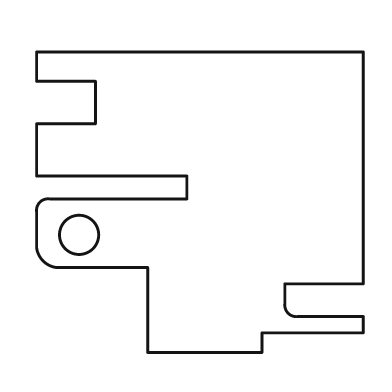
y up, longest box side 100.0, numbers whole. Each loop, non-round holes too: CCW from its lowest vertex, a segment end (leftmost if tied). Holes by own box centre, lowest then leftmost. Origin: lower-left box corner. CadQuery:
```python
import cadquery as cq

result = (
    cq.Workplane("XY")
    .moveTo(34.0, 0.0)
    .lineTo(69.0, 0.0)
    .lineTo(69.0, 6.0)
    .lineTo(100.0, 6.0)
    .lineTo(100.0, 11.0)
    .lineTo(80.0, 11.0)
    .threePointArc((77.0, 12.0), (76.0, 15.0))
    .lineTo(76.0, 21.0)
    .lineTo(100.0, 21.0)
    .lineTo(100.0, 92.0)
    .lineTo(0.0, 92.0)
    .lineTo(0.0, 83.0)
    .lineTo(18.0, 83.0)
    .lineTo(18.0, 70.0)
    .lineTo(0.0, 70.0)
    .lineTo(0.0, 54.0)
    .lineTo(46.0, 54.0)
    .lineTo(46.0, 47.0)
    .lineTo(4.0, 47.0)
    .threePointArc((1.0, 46.0), (0.0, 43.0))
    .lineTo(0.0, 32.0)
    .threePointArc((2.0, 28.0), (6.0, 26.0))
    .lineTo(34.0, 26.0)
    .close()
    .moveTo(13.0, 36.0)
    .circle(6.0)
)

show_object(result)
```